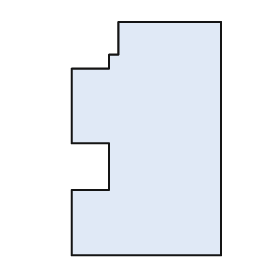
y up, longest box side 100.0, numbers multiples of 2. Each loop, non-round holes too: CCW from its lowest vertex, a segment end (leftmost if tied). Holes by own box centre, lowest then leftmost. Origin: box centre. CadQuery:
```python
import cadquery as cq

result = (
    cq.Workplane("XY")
    .moveTo(-32.0, -50.0)
    .lineTo(32.0, -50.0)
    .lineTo(32.0, 50.0)
    .lineTo(-12.0, 50.0)
    .lineTo(-12.0, 36.0)
    .lineTo(-16.0, 36.0)
    .lineTo(-16.0, 30.0)
    .lineTo(-32.0, 30.0)
    .lineTo(-32.0, -2.0)
    .lineTo(-16.0, -2.0)
    .lineTo(-16.0, -22.0)
    .lineTo(-32.0, -22.0)
    .close()
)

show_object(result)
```